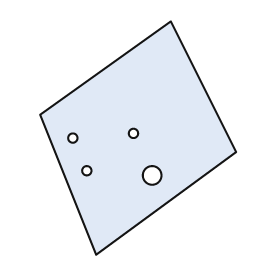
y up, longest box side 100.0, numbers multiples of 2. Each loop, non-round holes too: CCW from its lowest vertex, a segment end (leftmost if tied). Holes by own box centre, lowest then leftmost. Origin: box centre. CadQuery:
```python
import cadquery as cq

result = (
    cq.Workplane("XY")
    .moveTo(-18.0, -50.0)
    .lineTo(42.0, -6.0)
    .lineTo(14.0, 50.0)
    .lineTo(-42.0, 10.0)
    .close()
    .moveTo(6.0, -16.0)
    .circle(4.0)
    .moveTo(-22.0, -14.0)
    .circle(2.0)
    .moveTo(-28.0, 0.0)
    .circle(2.0)
    .moveTo(-2.0, 2.0)
    .circle(2.0)
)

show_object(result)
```